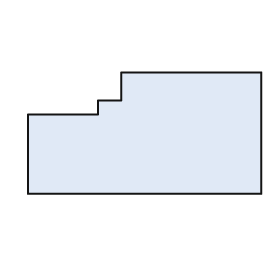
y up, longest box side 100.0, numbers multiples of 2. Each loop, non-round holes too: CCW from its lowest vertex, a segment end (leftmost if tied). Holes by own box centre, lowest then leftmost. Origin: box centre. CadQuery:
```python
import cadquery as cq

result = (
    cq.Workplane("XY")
    .moveTo(-50.0, -26.0)
    .lineTo(50.0, -26.0)
    .lineTo(50.0, 26.0)
    .lineTo(-10.0, 26.0)
    .lineTo(-10.0, 14.0)
    .lineTo(-20.0, 14.0)
    .lineTo(-20.0, 8.0)
    .lineTo(-50.0, 8.0)
    .close()
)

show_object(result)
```